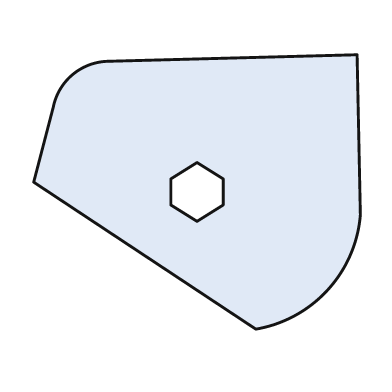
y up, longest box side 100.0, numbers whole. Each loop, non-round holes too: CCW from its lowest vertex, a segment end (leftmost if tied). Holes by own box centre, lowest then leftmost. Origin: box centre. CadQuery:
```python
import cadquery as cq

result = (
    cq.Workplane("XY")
    .moveTo(18.0, -42.0)
    .threePointArc((40.0, -30.0), (50.0, -7.0))
    .lineTo(49.0, 42.0)
    .lineTo(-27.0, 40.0)
    .threePointArc((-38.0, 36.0), (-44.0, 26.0))
    .lineTo(-50.0, 3.0)
    .close()
    .moveTo(0.0, -9.0)
    .lineTo(8.0, -4.0)
    .lineTo(8.0, 4.0)
    .lineTo(0.0, 9.0)
    .lineTo(-8.0, 4.0)
    .lineTo(-8.0, -4.0)
    .close()
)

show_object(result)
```